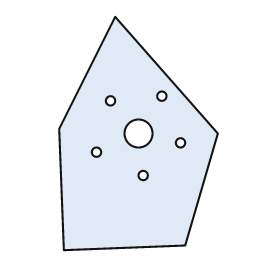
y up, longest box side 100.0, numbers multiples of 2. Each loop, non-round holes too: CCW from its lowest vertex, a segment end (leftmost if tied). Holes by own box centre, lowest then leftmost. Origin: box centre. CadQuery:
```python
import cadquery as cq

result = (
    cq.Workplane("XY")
    .moveTo(-32.0, -50.0)
    .lineTo(20.0, -48.0)
    .lineTo(34.0, 0.0)
    .lineTo(-10.0, 50.0)
    .lineTo(-34.0, 2.0)
    .close()
    .moveTo(2.0, -18.0)
    .circle(2.0)
    .moveTo(-18.0, -8.0)
    .circle(2.0)
    .moveTo(18.0, -4.0)
    .circle(2.0)
    .moveTo(0.0, 0.0)
    .circle(6.0)
    .moveTo(-12.0, 14.0)
    .circle(2.0)
    .moveTo(10.0, 16.0)
    .circle(2.0)
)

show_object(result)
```